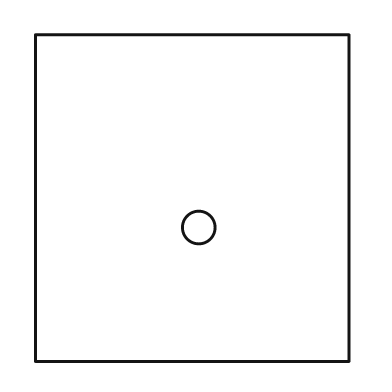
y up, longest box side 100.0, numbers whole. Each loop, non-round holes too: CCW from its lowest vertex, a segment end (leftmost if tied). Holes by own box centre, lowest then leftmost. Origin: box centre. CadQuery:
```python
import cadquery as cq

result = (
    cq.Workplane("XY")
    .moveTo(-48.0, -50.0)
    .lineTo(48.0, -50.0)
    .lineTo(48.0, 50.0)
    .lineTo(-48.0, 50.0)
    .close()
    .moveTo(2.0, -9.0)
    .circle(5.0)
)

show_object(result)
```